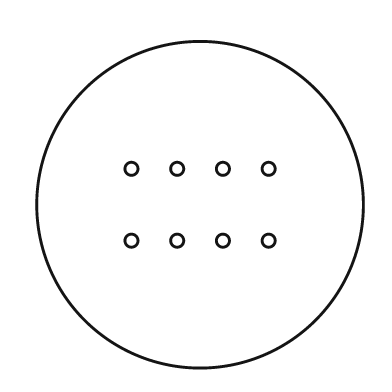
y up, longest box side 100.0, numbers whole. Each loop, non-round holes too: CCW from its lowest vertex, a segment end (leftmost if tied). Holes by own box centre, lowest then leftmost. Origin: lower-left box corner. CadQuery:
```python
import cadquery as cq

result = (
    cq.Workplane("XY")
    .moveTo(50.0, 50.0)
    .circle(50.0)
    .moveTo(29.0, 39.0)
    .circle(2.0)
    .moveTo(43.0, 39.0)
    .circle(2.0)
    .moveTo(57.0, 39.0)
    .circle(2.0)
    .moveTo(71.0, 39.0)
    .circle(2.0)
    .moveTo(29.0, 61.0)
    .circle(2.0)
    .moveTo(43.0, 61.0)
    .circle(2.0)
    .moveTo(57.0, 61.0)
    .circle(2.0)
    .moveTo(71.0, 61.0)
    .circle(2.0)
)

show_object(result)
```